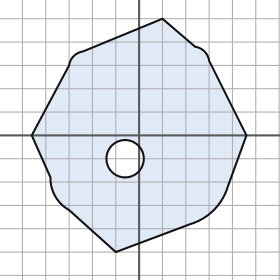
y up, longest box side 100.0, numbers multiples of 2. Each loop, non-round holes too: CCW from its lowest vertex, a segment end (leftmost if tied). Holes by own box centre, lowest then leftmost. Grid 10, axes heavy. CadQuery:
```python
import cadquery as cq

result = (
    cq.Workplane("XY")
    .moveTo(-10.0, -50.0)
    .lineTo(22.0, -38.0)
    .threePointArc((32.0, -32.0), (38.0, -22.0))
    .lineTo(46.0, 0.0)
    .lineTo(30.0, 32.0)
    .threePointArc((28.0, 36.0), (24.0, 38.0))
    .lineTo(10.0, 50.0)
    .lineTo(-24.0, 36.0)
    .threePointArc((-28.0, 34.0), (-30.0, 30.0))
    .lineTo(-46.0, 0.0)
    .lineTo(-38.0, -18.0)
    .threePointArc((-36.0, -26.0), (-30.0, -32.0))
    .close()
    .moveTo(-6.0, -10.0)
    .circle(8.0)
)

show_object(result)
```